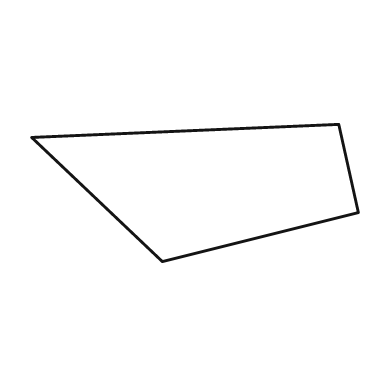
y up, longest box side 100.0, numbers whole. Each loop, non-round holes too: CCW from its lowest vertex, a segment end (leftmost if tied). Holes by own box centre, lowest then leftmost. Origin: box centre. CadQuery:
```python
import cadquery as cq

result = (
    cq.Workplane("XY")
    .moveTo(-10.0, -21.0)
    .lineTo(50.0, -6.0)
    .lineTo(44.0, 21.0)
    .lineTo(-50.0, 17.0)
    .close()
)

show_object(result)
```